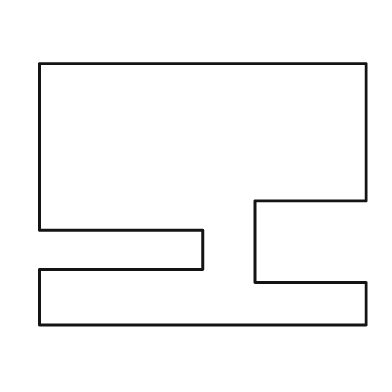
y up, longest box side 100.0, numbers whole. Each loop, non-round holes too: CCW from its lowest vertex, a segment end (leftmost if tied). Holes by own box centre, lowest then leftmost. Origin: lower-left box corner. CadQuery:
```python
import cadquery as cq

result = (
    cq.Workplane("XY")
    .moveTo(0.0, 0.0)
    .lineTo(100.0, 0.0)
    .lineTo(100.0, 13.0)
    .lineTo(66.0, 13.0)
    .lineTo(66.0, 38.0)
    .lineTo(100.0, 38.0)
    .lineTo(100.0, 80.0)
    .lineTo(0.0, 80.0)
    .lineTo(0.0, 29.0)
    .lineTo(50.0, 29.0)
    .lineTo(50.0, 17.0)
    .lineTo(0.0, 17.0)
    .close()
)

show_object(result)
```